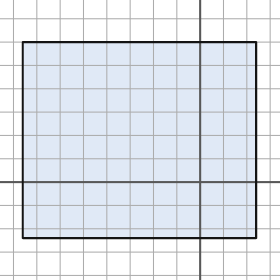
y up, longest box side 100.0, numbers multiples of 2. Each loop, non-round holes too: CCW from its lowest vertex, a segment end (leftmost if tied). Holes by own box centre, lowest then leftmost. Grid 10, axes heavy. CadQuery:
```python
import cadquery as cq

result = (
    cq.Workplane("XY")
    .moveTo(-76.0, -24.0)
    .lineTo(24.0, -24.0)
    .lineTo(24.0, 60.0)
    .lineTo(-76.0, 60.0)
    .close()
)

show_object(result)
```